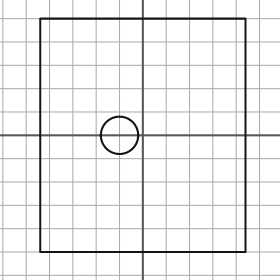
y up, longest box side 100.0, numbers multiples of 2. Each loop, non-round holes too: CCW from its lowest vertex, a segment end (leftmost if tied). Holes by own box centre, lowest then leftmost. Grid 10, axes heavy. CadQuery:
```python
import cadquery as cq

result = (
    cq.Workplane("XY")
    .moveTo(-44.0, -50.0)
    .lineTo(44.0, -50.0)
    .lineTo(44.0, 50.0)
    .lineTo(-44.0, 50.0)
    .close()
    .moveTo(-10.0, 0.0)
    .circle(8.0)
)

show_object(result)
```